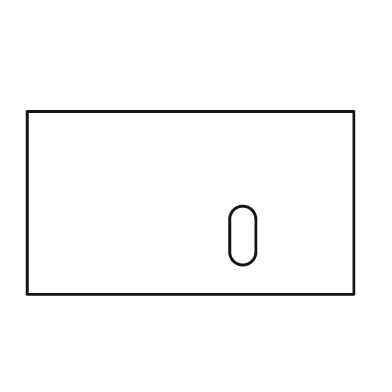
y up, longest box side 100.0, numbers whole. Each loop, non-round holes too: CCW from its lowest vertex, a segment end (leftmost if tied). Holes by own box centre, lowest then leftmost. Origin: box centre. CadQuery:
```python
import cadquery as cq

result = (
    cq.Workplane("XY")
    .moveTo(-50.0, -28.0)
    .lineTo(50.0, -28.0)
    .lineTo(50.0, 28.0)
    .lineTo(-50.0, 28.0)
    .close()
    .moveTo(12.0, -15.0)
    .threePointArc((16.0, -19.0), (20.0, -15.0))
    .lineTo(20.0, -5.0)
    .threePointArc((16.0, -1.0), (12.0, -5.0))
    .close()
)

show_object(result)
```